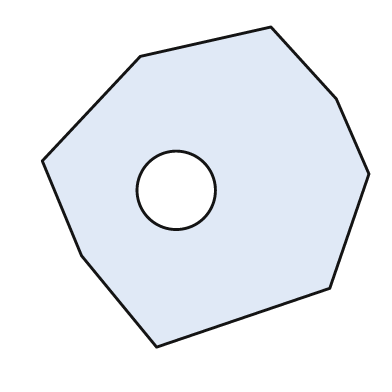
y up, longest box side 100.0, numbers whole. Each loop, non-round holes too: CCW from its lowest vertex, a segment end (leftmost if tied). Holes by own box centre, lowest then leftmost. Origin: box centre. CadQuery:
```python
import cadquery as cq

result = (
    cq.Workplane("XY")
    .moveTo(-15.0, -49.0)
    .lineTo(38.0, -31.0)
    .lineTo(50.0, 4.0)
    .lineTo(40.0, 27.0)
    .lineTo(20.0, 49.0)
    .lineTo(-20.0, 40.0)
    .lineTo(-50.0, 8.0)
    .lineTo(-38.0, -21.0)
    .close()
    .moveTo(-9.0, -1.0)
    .circle(12.0)
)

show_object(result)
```